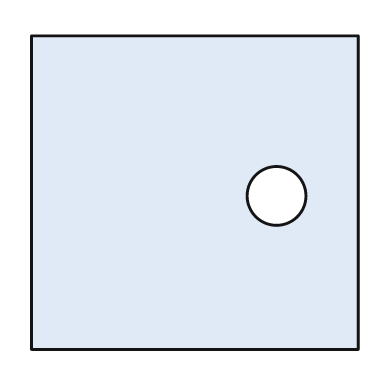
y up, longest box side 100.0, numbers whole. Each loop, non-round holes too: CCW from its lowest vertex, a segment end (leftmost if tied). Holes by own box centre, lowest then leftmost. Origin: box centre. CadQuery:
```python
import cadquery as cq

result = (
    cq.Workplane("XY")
    .moveTo(-50.0, -48.0)
    .lineTo(50.0, -48.0)
    .lineTo(50.0, 48.0)
    .lineTo(-50.0, 48.0)
    .close()
    .moveTo(25.0, -1.0)
    .circle(9.0)
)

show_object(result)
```